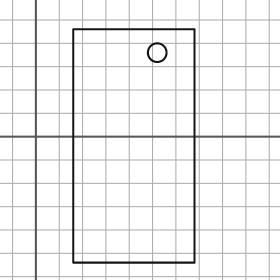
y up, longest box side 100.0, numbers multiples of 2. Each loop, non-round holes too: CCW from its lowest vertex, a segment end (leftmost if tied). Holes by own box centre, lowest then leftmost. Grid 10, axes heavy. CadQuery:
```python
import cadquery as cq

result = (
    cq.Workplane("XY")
    .moveTo(16.0, -54.0)
    .lineTo(68.0, -54.0)
    .lineTo(68.0, 46.0)
    .lineTo(16.0, 46.0)
    .close()
    .moveTo(52.0, 36.0)
    .circle(4.0)
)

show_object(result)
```